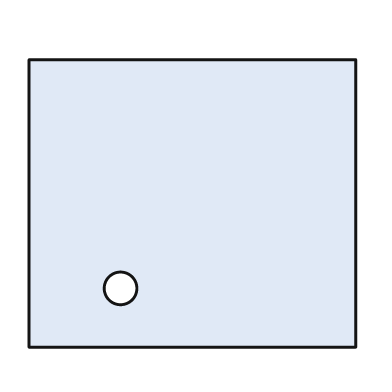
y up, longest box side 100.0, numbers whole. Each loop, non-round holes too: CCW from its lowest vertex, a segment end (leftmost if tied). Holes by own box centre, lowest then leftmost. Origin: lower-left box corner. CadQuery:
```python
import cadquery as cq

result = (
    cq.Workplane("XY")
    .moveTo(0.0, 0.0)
    .lineTo(100.0, 0.0)
    .lineTo(100.0, 88.0)
    .lineTo(0.0, 88.0)
    .close()
    .moveTo(28.0, 18.0)
    .circle(5.0)
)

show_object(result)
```